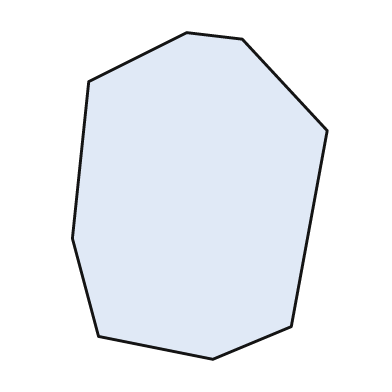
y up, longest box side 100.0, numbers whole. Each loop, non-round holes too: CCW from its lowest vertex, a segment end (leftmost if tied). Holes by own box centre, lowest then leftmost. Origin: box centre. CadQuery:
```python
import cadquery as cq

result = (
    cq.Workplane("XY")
    .moveTo(4.0, -50.0)
    .lineTo(28.0, -40.0)
    .lineTo(39.0, 20.0)
    .lineTo(13.0, 48.0)
    .lineTo(-4.0, 50.0)
    .lineTo(-34.0, 35.0)
    .lineTo(-39.0, -13.0)
    .lineTo(-31.0, -43.0)
    .close()
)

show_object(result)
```